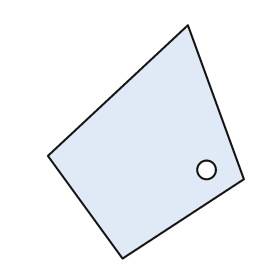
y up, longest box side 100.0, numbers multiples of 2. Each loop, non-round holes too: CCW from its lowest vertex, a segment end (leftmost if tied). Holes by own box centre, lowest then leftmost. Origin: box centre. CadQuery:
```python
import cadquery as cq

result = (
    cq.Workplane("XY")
    .moveTo(-10.0, -50.0)
    .lineTo(42.0, -16.0)
    .lineTo(18.0, 50.0)
    .lineTo(-42.0, -6.0)
    .close()
    .moveTo(26.0, -12.0)
    .circle(4.0)
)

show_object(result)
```